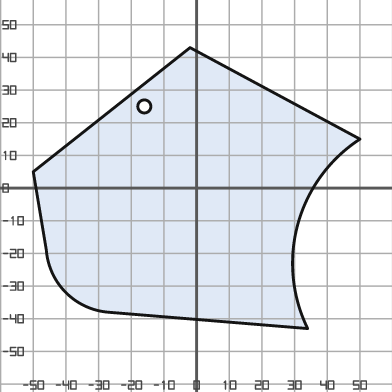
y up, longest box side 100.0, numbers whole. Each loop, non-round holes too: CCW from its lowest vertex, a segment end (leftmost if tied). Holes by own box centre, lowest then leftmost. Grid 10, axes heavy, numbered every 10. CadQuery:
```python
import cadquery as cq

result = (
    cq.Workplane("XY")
    .moveTo(34.0, -43.0)
    .threePointArc((31.0, -11.0), (50.0, 15.0))
    .lineTo(-2.0, 43.0)
    .lineTo(-50.0, 5.0)
    .lineTo(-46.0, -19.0)
    .threePointArc((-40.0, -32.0), (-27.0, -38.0))
    .close()
    .moveTo(-16.0, 25.0)
    .circle(2.0)
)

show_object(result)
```